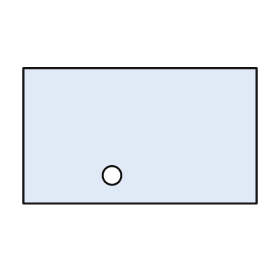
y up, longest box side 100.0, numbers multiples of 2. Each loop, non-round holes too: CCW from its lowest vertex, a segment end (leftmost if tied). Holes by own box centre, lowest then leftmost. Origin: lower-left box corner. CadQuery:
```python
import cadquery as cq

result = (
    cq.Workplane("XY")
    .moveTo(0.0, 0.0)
    .lineTo(100.0, 0.0)
    .lineTo(100.0, 58.0)
    .lineTo(0.0, 58.0)
    .close()
    .moveTo(38.0, 12.0)
    .circle(4.0)
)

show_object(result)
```